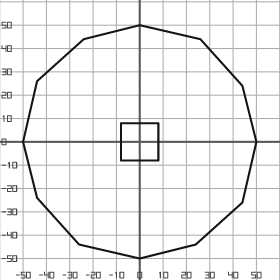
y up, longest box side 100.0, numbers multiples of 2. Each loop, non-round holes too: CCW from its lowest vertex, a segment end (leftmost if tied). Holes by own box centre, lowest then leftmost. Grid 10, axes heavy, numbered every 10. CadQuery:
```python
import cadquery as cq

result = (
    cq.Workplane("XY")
    .moveTo(0.0, -50.0)
    .lineTo(24.0, -44.0)
    .lineTo(44.0, -26.0)
    .lineTo(50.0, 0.0)
    .lineTo(44.0, 24.0)
    .lineTo(26.0, 44.0)
    .lineTo(0.0, 50.0)
    .lineTo(-24.0, 44.0)
    .lineTo(-44.0, 26.0)
    .lineTo(-50.0, 0.0)
    .lineTo(-44.0, -24.0)
    .lineTo(-26.0, -44.0)
    .close()
    .moveTo(-8.0, -8.0)
    .lineTo(8.0, -8.0)
    .lineTo(8.0, 8.0)
    .lineTo(-8.0, 8.0)
    .close()
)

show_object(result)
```